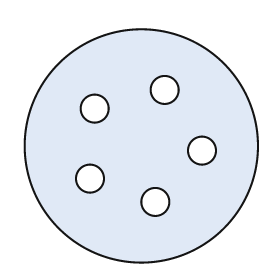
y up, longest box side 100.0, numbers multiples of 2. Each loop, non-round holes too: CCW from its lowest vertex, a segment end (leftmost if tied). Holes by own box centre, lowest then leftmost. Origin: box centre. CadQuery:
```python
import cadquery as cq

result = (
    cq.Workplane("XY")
    .moveTo(0.0, 0.0)
    .circle(50.0)
    .moveTo(6.0, -24.0)
    .circle(6.0)
    .moveTo(-22.0, -14.0)
    .circle(6.0)
    .moveTo(26.0, -2.0)
    .circle(6.0)
    .moveTo(-20.0, 16.0)
    .circle(6.0)
    .moveTo(10.0, 24.0)
    .circle(6.0)
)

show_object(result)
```